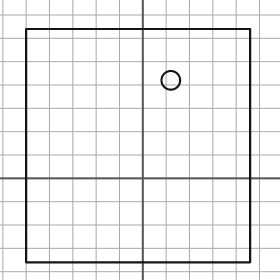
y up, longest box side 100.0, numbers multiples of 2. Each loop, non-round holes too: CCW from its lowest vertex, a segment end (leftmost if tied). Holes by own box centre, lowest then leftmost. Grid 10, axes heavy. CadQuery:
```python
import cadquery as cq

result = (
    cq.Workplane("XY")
    .moveTo(-50.0, -36.0)
    .lineTo(46.0, -36.0)
    .lineTo(46.0, 64.0)
    .lineTo(-50.0, 64.0)
    .close()
    .moveTo(12.0, 42.0)
    .circle(4.0)
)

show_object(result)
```